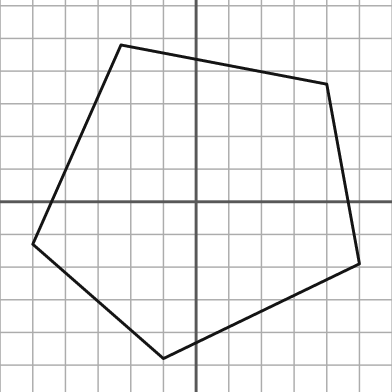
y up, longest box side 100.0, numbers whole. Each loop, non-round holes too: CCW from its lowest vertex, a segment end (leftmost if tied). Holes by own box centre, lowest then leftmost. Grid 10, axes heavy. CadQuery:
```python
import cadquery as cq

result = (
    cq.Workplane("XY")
    .moveTo(-10.0, -48.0)
    .lineTo(50.0, -19.0)
    .lineTo(40.0, 36.0)
    .lineTo(-23.0, 48.0)
    .lineTo(-50.0, -13.0)
    .close()
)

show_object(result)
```